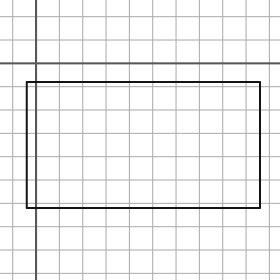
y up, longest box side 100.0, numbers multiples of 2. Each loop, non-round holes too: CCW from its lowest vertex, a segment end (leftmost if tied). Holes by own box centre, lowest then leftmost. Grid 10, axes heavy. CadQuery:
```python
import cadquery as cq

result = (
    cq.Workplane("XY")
    .moveTo(-4.0, -62.0)
    .lineTo(96.0, -62.0)
    .lineTo(96.0, -8.0)
    .lineTo(-4.0, -8.0)
    .close()
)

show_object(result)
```